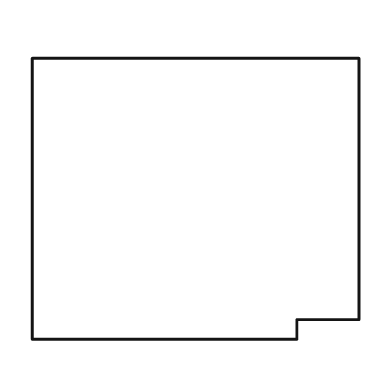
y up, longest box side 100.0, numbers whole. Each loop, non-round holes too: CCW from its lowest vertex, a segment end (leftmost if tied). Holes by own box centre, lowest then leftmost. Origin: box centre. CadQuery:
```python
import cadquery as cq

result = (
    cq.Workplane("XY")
    .moveTo(-50.0, -43.0)
    .lineTo(31.0, -43.0)
    .lineTo(31.0, -37.0)
    .lineTo(50.0, -37.0)
    .lineTo(50.0, 43.0)
    .lineTo(-50.0, 43.0)
    .close()
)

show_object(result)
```